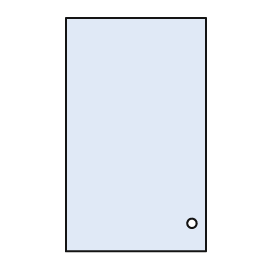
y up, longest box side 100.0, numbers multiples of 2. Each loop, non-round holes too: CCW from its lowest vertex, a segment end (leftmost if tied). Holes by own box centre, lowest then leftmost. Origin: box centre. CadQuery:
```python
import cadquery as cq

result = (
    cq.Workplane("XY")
    .moveTo(-30.0, -50.0)
    .lineTo(30.0, -50.0)
    .lineTo(30.0, 50.0)
    .lineTo(-30.0, 50.0)
    .close()
    .moveTo(24.0, -38.0)
    .circle(2.0)
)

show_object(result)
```